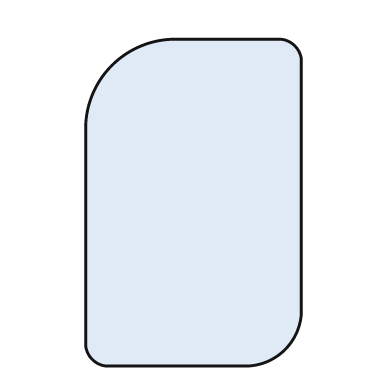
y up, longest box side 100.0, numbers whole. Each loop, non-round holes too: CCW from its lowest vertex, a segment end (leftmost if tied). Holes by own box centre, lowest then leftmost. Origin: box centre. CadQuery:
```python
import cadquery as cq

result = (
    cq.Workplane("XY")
    .moveTo(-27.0, -50.0)
    .lineTo(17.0, -50.0)
    .threePointArc((28.0, -45.0), (33.0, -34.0))
    .lineTo(33.0, 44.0)
    .threePointArc((31.0, 48.0), (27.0, 50.0))
    .lineTo(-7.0, 50.0)
    .threePointArc((-25.0, 42.0), (-33.0, 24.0))
    .lineTo(-33.0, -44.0)
    .threePointArc((-31.0, -48.0), (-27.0, -50.0))
    .close()
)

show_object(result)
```